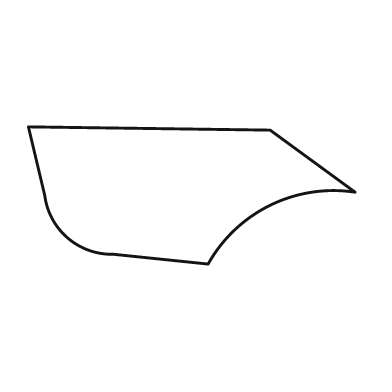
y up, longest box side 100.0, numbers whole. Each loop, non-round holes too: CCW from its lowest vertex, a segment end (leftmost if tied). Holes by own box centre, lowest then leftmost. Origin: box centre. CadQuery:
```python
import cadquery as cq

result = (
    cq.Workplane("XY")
    .moveTo(5.0, -21.0)
    .threePointArc((24.0, -3.0), (50.0, 1.0))
    .lineTo(24.0, 20.0)
    .lineTo(-50.0, 21.0)
    .lineTo(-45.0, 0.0)
    .threePointArc((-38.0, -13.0), (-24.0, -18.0))
    .close()
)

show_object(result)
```